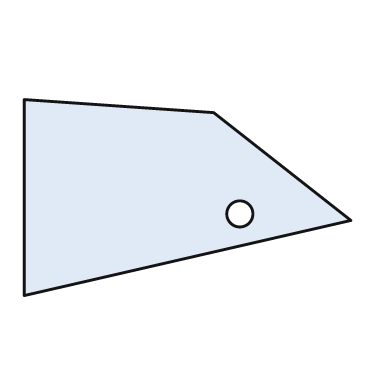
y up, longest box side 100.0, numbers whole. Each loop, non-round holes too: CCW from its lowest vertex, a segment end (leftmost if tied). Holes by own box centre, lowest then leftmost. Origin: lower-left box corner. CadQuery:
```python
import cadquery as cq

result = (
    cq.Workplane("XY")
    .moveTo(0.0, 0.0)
    .lineTo(100.0, 23.0)
    .lineTo(58.0, 56.0)
    .lineTo(0.0, 60.0)
    .close()
    .moveTo(66.0, 25.0)
    .circle(4.0)
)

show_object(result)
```